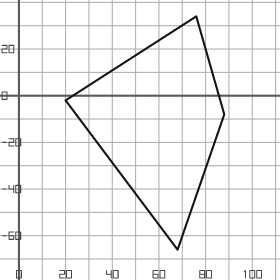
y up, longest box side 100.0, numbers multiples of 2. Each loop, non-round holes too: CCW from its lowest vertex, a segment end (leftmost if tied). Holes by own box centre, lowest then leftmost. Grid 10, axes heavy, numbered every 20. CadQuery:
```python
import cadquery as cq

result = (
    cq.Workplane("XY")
    .moveTo(68.0, -66.0)
    .lineTo(88.0, -8.0)
    .lineTo(76.0, 34.0)
    .lineTo(20.0, -2.0)
    .close()
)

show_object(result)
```